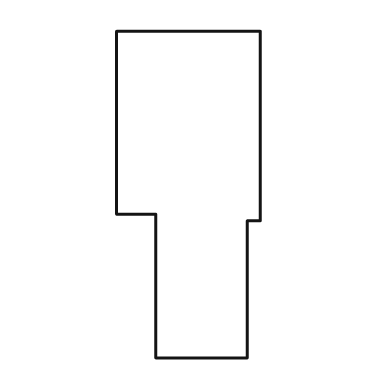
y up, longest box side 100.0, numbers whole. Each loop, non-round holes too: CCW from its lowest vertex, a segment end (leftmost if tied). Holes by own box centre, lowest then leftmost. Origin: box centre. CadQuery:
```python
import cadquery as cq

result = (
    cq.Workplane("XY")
    .moveTo(-10.0, -50.0)
    .lineTo(18.0, -50.0)
    .lineTo(18.0, -8.0)
    .lineTo(22.0, -8.0)
    .lineTo(22.0, 50.0)
    .lineTo(-22.0, 50.0)
    .lineTo(-22.0, -6.0)
    .lineTo(-10.0, -6.0)
    .close()
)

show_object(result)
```